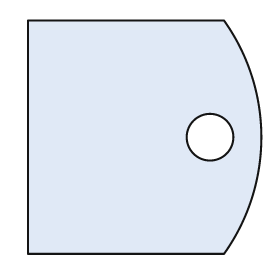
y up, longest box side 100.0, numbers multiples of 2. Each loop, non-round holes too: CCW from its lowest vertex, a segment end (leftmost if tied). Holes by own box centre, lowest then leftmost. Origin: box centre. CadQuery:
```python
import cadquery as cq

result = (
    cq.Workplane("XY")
    .moveTo(-50.0, -50.0)
    .lineTo(34.0, -50.0)
    .threePointArc((50.0, 0.0), (34.0, 50.0))
    .lineTo(-50.0, 50.0)
    .close()
    .moveTo(28.0, 0.0)
    .circle(10.0)
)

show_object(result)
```